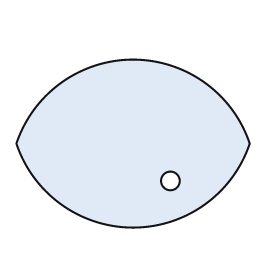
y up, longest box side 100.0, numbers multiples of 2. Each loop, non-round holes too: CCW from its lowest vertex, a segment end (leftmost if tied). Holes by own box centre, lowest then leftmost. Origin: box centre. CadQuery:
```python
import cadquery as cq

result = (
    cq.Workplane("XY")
    .moveTo(-50.0, 0.0)
    .threePointArc((0.0, -36.0), (50.0, 0.0))
    .threePointArc((0.0, 36.0), (-50.0, 0.0))
    .close()
    .moveTo(16.0, -16.0)
    .circle(4.0)
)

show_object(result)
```